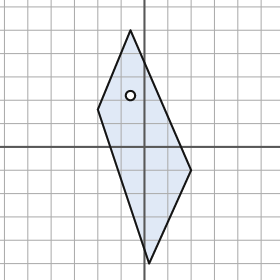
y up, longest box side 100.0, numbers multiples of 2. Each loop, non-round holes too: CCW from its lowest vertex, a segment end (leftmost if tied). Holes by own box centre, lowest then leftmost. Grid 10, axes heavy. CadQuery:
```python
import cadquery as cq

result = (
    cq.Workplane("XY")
    .moveTo(2.0, -50.0)
    .lineTo(20.0, -10.0)
    .lineTo(-6.0, 50.0)
    .lineTo(-20.0, 16.0)
    .close()
    .moveTo(-6.0, 22.0)
    .circle(2.0)
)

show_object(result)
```